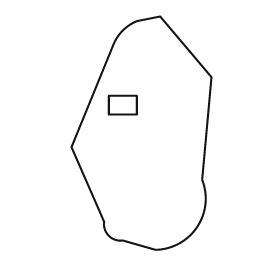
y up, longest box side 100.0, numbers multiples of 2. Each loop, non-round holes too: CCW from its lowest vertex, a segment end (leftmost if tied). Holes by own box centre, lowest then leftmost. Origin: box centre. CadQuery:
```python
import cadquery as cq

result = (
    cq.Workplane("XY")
    .moveTo(6.0, -50.0)
    .threePointArc((24.0, -40.0), (26.0, -20.0))
    .lineTo(30.0, 24.0)
    .lineTo(8.0, 50.0)
    .lineTo(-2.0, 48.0)
    .threePointArc((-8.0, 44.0), (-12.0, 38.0))
    .lineTo(-30.0, -6.0)
    .lineTo(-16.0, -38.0)
    .threePointArc((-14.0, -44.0), (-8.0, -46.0))
    .close()
    .moveTo(-14.0, 8.0)
    .lineTo(-2.0, 8.0)
    .lineTo(-2.0, 16.0)
    .lineTo(-14.0, 16.0)
    .close()
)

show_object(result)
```